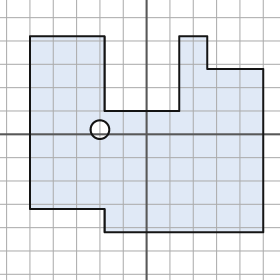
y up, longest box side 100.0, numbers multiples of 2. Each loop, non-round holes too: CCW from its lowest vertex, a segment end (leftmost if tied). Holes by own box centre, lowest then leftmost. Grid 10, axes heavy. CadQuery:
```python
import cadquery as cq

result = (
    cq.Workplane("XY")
    .moveTo(-18.0, -42.0)
    .lineTo(50.0, -42.0)
    .lineTo(50.0, 28.0)
    .lineTo(26.0, 28.0)
    .lineTo(26.0, 42.0)
    .lineTo(14.0, 42.0)
    .lineTo(14.0, 10.0)
    .lineTo(-18.0, 10.0)
    .lineTo(-18.0, 42.0)
    .lineTo(-50.0, 42.0)
    .lineTo(-50.0, -32.0)
    .lineTo(-18.0, -32.0)
    .close()
    .moveTo(-20.0, 2.0)
    .circle(4.0)
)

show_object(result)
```